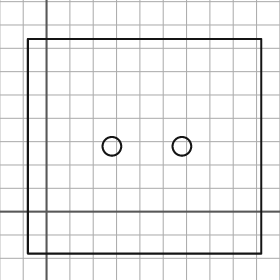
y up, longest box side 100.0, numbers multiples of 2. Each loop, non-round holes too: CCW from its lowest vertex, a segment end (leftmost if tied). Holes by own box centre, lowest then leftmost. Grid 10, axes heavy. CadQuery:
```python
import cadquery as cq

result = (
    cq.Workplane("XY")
    .moveTo(-8.0, -18.0)
    .lineTo(92.0, -18.0)
    .lineTo(92.0, 74.0)
    .lineTo(-8.0, 74.0)
    .close()
    .moveTo(28.0, 28.0)
    .circle(4.0)
    .moveTo(58.0, 28.0)
    .circle(4.0)
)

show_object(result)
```